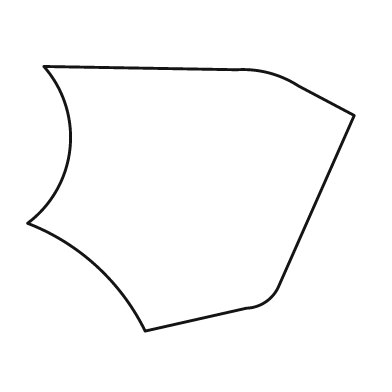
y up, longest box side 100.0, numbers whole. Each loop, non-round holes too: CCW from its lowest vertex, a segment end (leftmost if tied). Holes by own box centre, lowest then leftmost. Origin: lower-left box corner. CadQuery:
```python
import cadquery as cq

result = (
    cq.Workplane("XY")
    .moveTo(36.0, 0.0)
    .lineTo(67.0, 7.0)
    .threePointArc((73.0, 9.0), (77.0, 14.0))
    .lineTo(100.0, 66.0)
    .lineTo(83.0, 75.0)
    .threePointArc((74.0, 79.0), (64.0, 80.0))
    .lineTo(5.0, 81.0)
    .threePointArc((13.0, 56.0), (0.0, 33.0))
    .threePointArc((21.0, 20.0), (36.0, 0.0))
    .close()
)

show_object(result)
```